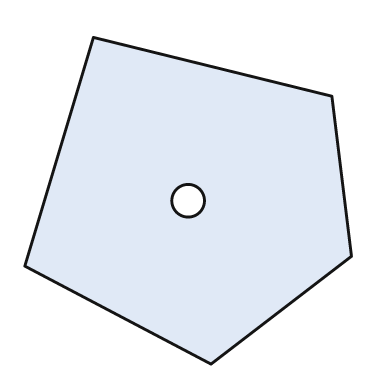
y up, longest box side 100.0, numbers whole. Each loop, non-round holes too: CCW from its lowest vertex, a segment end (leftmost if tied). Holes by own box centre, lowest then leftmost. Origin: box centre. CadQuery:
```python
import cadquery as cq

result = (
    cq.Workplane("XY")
    .moveTo(7.0, -50.0)
    .lineTo(50.0, -17.0)
    .lineTo(44.0, 32.0)
    .lineTo(-29.0, 50.0)
    .lineTo(-50.0, -20.0)
    .close()
    .moveTo(0.0, 0.0)
    .circle(5.0)
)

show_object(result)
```